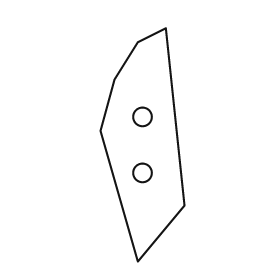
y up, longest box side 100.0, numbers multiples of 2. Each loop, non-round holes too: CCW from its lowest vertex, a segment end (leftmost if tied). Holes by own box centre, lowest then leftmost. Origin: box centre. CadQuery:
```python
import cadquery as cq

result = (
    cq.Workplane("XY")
    .moveTo(-2.0, -50.0)
    .lineTo(18.0, -26.0)
    .lineTo(10.0, 50.0)
    .lineTo(-2.0, 44.0)
    .lineTo(-12.0, 28.0)
    .lineTo(-18.0, 6.0)
    .close()
    .moveTo(0.0, -12.0)
    .circle(4.0)
    .moveTo(0.0, 12.0)
    .circle(4.0)
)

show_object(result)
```